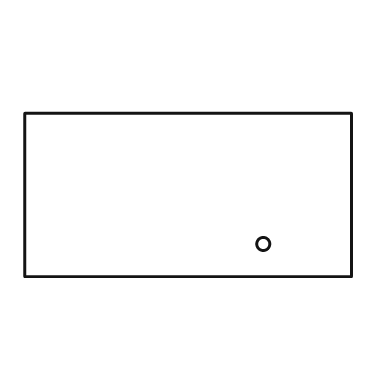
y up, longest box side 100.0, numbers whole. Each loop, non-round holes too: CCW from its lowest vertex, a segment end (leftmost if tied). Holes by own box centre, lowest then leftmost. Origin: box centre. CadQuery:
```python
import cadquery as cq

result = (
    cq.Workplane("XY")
    .moveTo(-50.0, -25.0)
    .lineTo(50.0, -25.0)
    .lineTo(50.0, 25.0)
    .lineTo(-50.0, 25.0)
    .close()
    .moveTo(23.0, -15.0)
    .circle(2.0)
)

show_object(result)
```